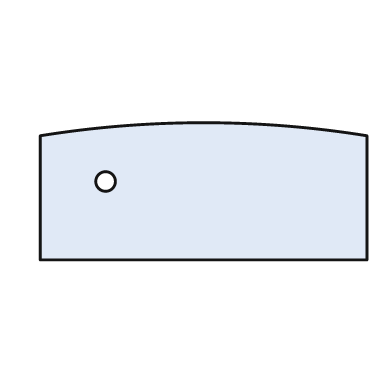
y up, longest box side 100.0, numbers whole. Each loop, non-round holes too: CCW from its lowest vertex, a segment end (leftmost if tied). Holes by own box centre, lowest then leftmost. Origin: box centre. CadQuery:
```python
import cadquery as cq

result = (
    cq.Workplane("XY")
    .moveTo(-50.0, -21.0)
    .lineTo(50.0, -21.0)
    .lineTo(50.0, 17.0)
    .threePointArc((0.0, 21.0), (-50.0, 17.0))
    .close()
    .moveTo(-30.0, 3.0)
    .circle(3.0)
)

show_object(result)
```